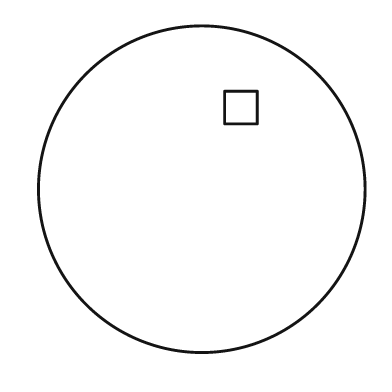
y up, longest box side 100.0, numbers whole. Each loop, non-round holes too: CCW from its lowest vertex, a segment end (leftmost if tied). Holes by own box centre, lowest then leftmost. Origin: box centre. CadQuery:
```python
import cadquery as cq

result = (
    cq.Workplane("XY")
    .moveTo(0.0, 0.0)
    .circle(50.0)
    .moveTo(7.0, 20.0)
    .lineTo(17.0, 20.0)
    .lineTo(17.0, 30.0)
    .lineTo(7.0, 30.0)
    .close()
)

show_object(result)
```